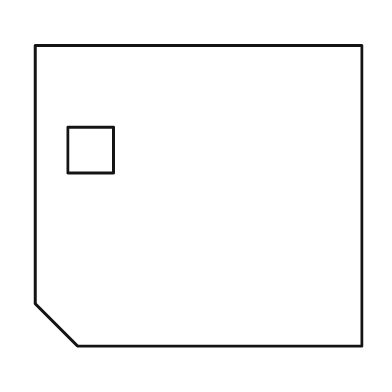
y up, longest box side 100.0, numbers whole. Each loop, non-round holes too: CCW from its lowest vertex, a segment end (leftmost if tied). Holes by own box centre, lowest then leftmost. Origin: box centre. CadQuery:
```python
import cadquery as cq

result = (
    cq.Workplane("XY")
    .moveTo(-37.0, -46.0)
    .lineTo(50.0, -46.0)
    .lineTo(50.0, 46.0)
    .lineTo(-50.0, 46.0)
    .lineTo(-50.0, -33.0)
    .close()
    .moveTo(-40.0, 7.0)
    .lineTo(-26.0, 7.0)
    .lineTo(-26.0, 21.0)
    .lineTo(-40.0, 21.0)
    .close()
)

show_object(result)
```